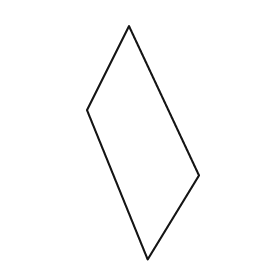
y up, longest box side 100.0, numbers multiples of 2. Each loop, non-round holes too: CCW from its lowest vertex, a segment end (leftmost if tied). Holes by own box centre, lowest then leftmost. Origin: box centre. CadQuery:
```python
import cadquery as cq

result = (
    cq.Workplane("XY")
    .moveTo(2.0, -50.0)
    .lineTo(24.0, -14.0)
    .lineTo(-6.0, 50.0)
    .lineTo(-24.0, 14.0)
    .close()
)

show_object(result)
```